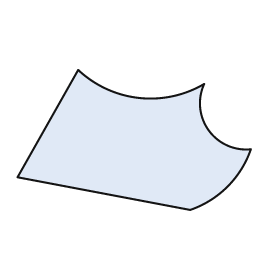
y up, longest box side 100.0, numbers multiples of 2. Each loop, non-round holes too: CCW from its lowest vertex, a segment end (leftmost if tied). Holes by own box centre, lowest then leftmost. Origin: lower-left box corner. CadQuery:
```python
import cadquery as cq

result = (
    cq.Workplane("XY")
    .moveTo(74.0, 0.0)
    .threePointArc((90.0, 10.0), (100.0, 26.0))
    .threePointArc((82.0, 34.0), (80.0, 54.0))
    .threePointArc((52.0, 48.0), (26.0, 60.0))
    .lineTo(0.0, 14.0)
    .close()
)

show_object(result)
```